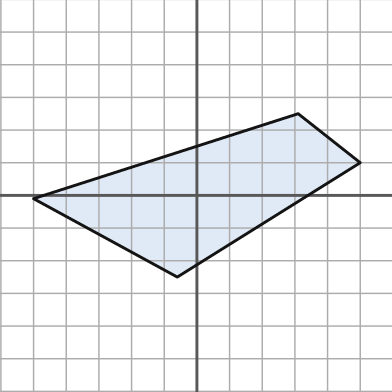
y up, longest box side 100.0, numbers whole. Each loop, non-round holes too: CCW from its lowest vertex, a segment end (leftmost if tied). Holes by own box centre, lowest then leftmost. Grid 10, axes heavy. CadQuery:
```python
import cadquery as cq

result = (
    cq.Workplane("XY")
    .moveTo(-6.0, -25.0)
    .lineTo(50.0, 10.0)
    .lineTo(31.0, 25.0)
    .lineTo(-50.0, -1.0)
    .close()
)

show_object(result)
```